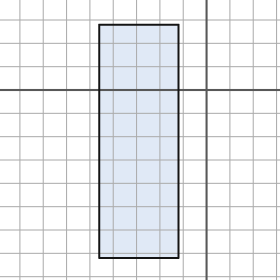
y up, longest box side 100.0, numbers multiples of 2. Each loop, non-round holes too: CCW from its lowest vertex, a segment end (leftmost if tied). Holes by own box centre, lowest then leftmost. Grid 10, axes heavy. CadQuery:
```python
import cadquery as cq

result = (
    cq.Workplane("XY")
    .moveTo(-46.0, -72.0)
    .lineTo(-12.0, -72.0)
    .lineTo(-12.0, 28.0)
    .lineTo(-46.0, 28.0)
    .close()
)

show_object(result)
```